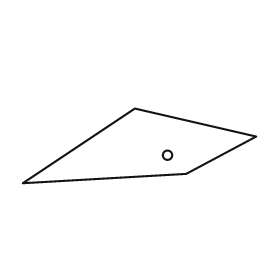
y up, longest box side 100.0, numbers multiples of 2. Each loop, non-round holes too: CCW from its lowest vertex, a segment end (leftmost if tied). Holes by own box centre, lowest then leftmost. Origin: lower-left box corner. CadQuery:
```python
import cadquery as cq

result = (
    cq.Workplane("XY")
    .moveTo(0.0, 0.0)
    .lineTo(70.0, 4.0)
    .lineTo(100.0, 20.0)
    .lineTo(48.0, 32.0)
    .close()
    .moveTo(62.0, 12.0)
    .circle(2.0)
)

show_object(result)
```